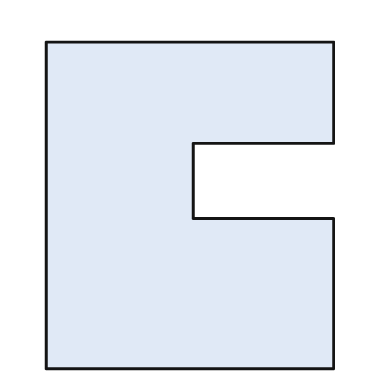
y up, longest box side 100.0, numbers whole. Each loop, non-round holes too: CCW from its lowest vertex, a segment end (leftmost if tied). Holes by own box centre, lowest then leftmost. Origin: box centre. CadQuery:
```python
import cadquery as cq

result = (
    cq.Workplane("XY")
    .moveTo(-44.0, -50.0)
    .lineTo(44.0, -50.0)
    .lineTo(44.0, -4.0)
    .lineTo(1.0, -4.0)
    .lineTo(1.0, 19.0)
    .lineTo(44.0, 19.0)
    .lineTo(44.0, 50.0)
    .lineTo(-44.0, 50.0)
    .close()
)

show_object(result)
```